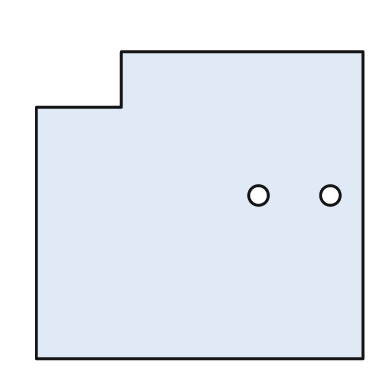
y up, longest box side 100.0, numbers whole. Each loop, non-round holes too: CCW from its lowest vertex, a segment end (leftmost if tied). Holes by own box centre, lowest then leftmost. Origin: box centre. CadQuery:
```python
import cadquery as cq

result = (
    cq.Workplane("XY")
    .moveTo(-50.0, -47.0)
    .lineTo(50.0, -47.0)
    .lineTo(50.0, 47.0)
    .lineTo(-24.0, 47.0)
    .lineTo(-24.0, 30.0)
    .lineTo(-50.0, 30.0)
    .close()
    .moveTo(18.0, 3.0)
    .circle(3.0)
    .moveTo(40.0, 3.0)
    .circle(3.0)
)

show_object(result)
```